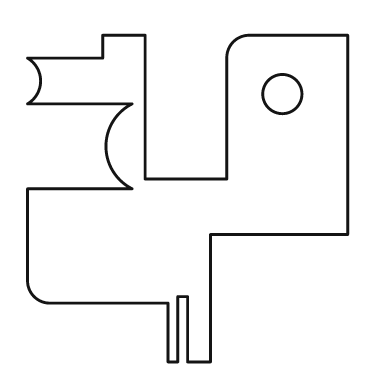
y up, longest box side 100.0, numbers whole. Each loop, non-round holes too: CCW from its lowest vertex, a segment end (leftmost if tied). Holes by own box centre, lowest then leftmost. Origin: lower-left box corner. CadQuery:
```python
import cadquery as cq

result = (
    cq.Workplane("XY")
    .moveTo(43.0, 0.0)
    .lineTo(46.0, 0.0)
    .lineTo(46.0, 20.0)
    .lineTo(49.0, 20.0)
    .lineTo(49.0, 0.0)
    .lineTo(56.0, 0.0)
    .lineTo(56.0, 39.0)
    .lineTo(98.0, 39.0)
    .lineTo(98.0, 100.0)
    .lineTo(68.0, 100.0)
    .threePointArc((63.0, 98.0), (61.0, 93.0))
    .lineTo(61.0, 56.0)
    .lineTo(36.0, 56.0)
    .lineTo(36.0, 100.0)
    .lineTo(23.0, 100.0)
    .lineTo(23.0, 93.0)
    .lineTo(0.0, 93.0)
    .threePointArc((4.0, 86.0), (0.0, 79.0))
    .lineTo(32.0, 79.0)
    .threePointArc((24.0, 66.0), (32.0, 53.0))
    .lineTo(0.0, 53.0)
    .lineTo(0.0, 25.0)
    .threePointArc((2.0, 20.0), (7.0, 18.0))
    .lineTo(43.0, 18.0)
    .close()
    .moveTo(78.0, 82.0)
    .circle(6.0)
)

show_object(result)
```